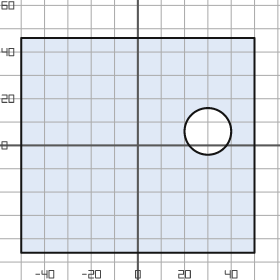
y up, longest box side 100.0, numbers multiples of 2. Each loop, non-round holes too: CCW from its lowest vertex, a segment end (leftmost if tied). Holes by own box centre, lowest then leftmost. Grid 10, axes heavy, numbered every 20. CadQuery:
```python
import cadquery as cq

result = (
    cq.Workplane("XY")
    .moveTo(-50.0, -46.0)
    .lineTo(50.0, -46.0)
    .lineTo(50.0, 46.0)
    .lineTo(-50.0, 46.0)
    .close()
    .moveTo(30.0, 6.0)
    .circle(10.0)
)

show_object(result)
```